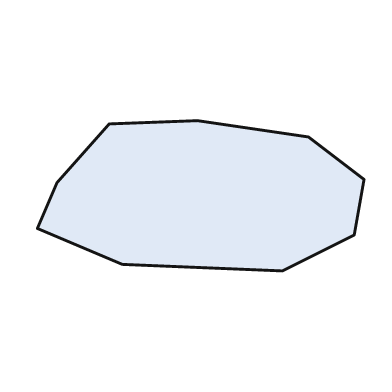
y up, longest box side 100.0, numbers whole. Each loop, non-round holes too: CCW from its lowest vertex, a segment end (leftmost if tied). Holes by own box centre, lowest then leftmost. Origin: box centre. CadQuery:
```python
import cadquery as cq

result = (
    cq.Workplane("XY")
    .moveTo(25.0, -23.0)
    .lineTo(47.0, -12.0)
    .lineTo(50.0, 5.0)
    .lineTo(33.0, 18.0)
    .lineTo(-1.0, 23.0)
    .lineTo(-28.0, 22.0)
    .lineTo(-44.0, 4.0)
    .lineTo(-50.0, -10.0)
    .lineTo(-24.0, -21.0)
    .close()
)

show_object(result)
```